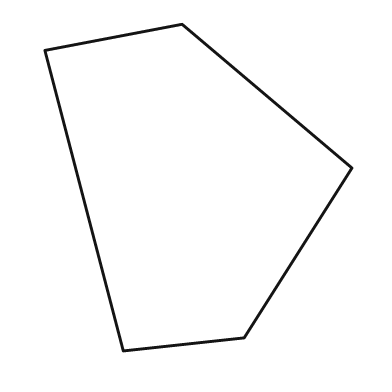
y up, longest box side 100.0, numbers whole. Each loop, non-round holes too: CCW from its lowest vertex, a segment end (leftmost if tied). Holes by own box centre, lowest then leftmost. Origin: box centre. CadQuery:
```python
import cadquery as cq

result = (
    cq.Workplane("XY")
    .moveTo(-23.0, -50.0)
    .lineTo(14.0, -46.0)
    .lineTo(47.0, 6.0)
    .lineTo(-5.0, 50.0)
    .lineTo(-47.0, 42.0)
    .close()
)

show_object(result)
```